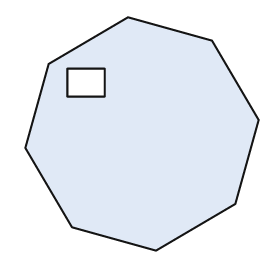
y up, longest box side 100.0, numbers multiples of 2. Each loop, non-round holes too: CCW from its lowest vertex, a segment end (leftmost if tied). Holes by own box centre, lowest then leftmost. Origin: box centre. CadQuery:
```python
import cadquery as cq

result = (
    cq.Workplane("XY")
    .moveTo(6.0, -50.0)
    .lineTo(40.0, -30.0)
    .lineTo(50.0, 6.0)
    .lineTo(30.0, 40.0)
    .lineTo(-6.0, 50.0)
    .lineTo(-40.0, 30.0)
    .lineTo(-50.0, -6.0)
    .lineTo(-30.0, -40.0)
    .close()
    .moveTo(-32.0, 16.0)
    .lineTo(-16.0, 16.0)
    .lineTo(-16.0, 28.0)
    .lineTo(-32.0, 28.0)
    .close()
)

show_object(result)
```